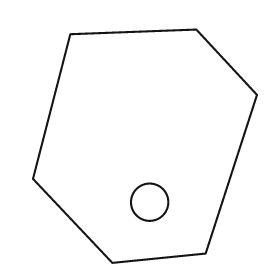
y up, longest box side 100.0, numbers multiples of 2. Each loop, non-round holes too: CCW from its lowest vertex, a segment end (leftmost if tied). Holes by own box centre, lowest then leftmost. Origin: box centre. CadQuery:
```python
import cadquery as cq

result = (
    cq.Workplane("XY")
    .moveTo(-14.0, -50.0)
    .lineTo(26.0, -46.0)
    .lineTo(48.0, 22.0)
    .lineTo(22.0, 50.0)
    .lineTo(-32.0, 48.0)
    .lineTo(-48.0, -14.0)
    .close()
    .moveTo(2.0, -24.0)
    .circle(8.0)
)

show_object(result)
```